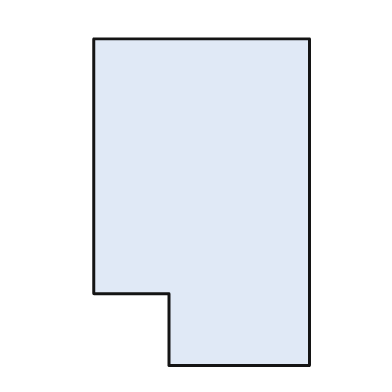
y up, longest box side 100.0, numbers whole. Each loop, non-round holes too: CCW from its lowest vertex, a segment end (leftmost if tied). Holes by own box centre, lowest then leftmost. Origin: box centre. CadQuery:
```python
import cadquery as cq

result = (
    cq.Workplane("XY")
    .moveTo(-10.0, -50.0)
    .lineTo(33.0, -50.0)
    .lineTo(33.0, 50.0)
    .lineTo(-33.0, 50.0)
    .lineTo(-33.0, -28.0)
    .lineTo(-10.0, -28.0)
    .close()
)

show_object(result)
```